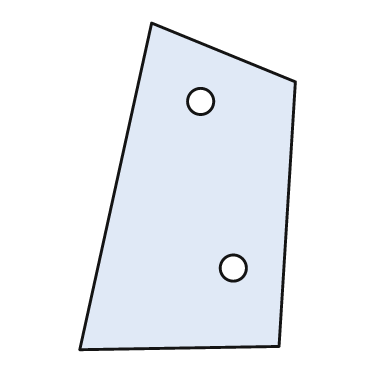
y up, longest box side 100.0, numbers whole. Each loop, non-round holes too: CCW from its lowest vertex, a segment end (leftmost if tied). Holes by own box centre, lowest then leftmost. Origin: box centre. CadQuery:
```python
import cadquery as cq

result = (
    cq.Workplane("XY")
    .moveTo(-33.0, -50.0)
    .lineTo(28.0, -49.0)
    .lineTo(33.0, 32.0)
    .lineTo(-11.0, 50.0)
    .close()
    .moveTo(14.0, -25.0)
    .circle(4.0)
    .moveTo(4.0, 26.0)
    .circle(4.0)
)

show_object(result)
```